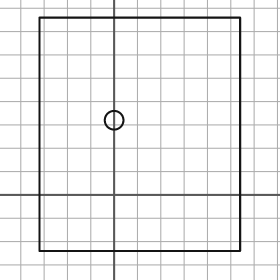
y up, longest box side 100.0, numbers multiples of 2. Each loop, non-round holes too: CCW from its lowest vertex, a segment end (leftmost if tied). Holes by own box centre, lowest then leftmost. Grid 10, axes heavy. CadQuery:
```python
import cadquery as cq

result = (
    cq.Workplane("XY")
    .moveTo(-32.0, -24.0)
    .lineTo(54.0, -24.0)
    .lineTo(54.0, 76.0)
    .lineTo(-32.0, 76.0)
    .close()
    .moveTo(0.0, 32.0)
    .circle(4.0)
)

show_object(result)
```